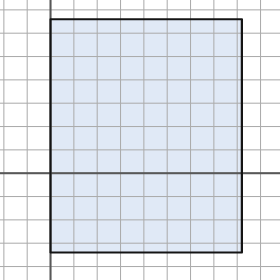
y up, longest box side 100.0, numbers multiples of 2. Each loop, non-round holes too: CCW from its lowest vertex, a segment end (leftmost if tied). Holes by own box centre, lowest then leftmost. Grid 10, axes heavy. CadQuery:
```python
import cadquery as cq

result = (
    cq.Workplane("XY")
    .moveTo(0.0, -34.0)
    .lineTo(82.0, -34.0)
    .lineTo(82.0, 66.0)
    .lineTo(0.0, 66.0)
    .close()
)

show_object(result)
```